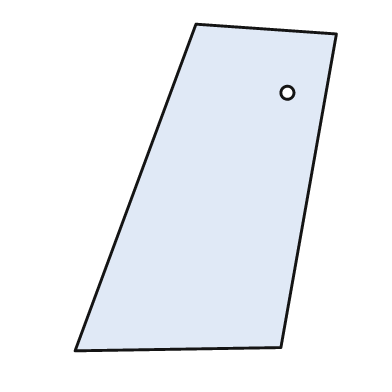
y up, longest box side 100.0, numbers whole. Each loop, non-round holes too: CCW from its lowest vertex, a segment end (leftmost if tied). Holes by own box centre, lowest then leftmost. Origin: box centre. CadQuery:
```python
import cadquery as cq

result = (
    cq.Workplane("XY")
    .moveTo(-40.0, -50.0)
    .lineTo(23.0, -49.0)
    .lineTo(40.0, 47.0)
    .lineTo(-3.0, 50.0)
    .close()
    .moveTo(25.0, 29.0)
    .circle(2.0)
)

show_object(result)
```